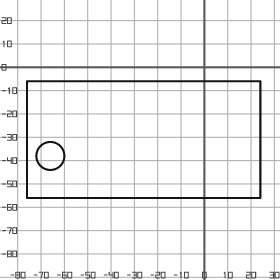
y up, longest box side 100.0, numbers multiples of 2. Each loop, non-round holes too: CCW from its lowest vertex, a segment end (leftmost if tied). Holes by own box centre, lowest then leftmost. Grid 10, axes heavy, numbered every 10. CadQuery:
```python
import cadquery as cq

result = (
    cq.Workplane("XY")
    .moveTo(-76.0, -56.0)
    .lineTo(24.0, -56.0)
    .lineTo(24.0, -6.0)
    .lineTo(-76.0, -6.0)
    .close()
    .moveTo(-66.0, -38.0)
    .circle(6.0)
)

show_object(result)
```